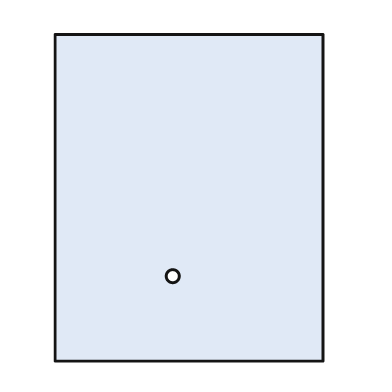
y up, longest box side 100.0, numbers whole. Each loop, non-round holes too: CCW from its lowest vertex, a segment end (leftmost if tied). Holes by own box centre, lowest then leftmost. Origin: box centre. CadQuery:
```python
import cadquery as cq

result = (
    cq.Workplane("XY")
    .moveTo(-41.0, -50.0)
    .lineTo(41.0, -50.0)
    .lineTo(41.0, 50.0)
    .lineTo(-41.0, 50.0)
    .close()
    .moveTo(-5.0, -24.0)
    .circle(2.0)
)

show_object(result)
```